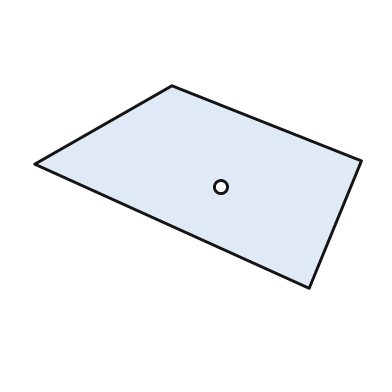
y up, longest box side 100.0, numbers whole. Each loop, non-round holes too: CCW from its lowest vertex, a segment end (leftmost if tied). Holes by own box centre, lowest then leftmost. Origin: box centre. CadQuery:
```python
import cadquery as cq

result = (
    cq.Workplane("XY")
    .moveTo(34.0, -31.0)
    .lineTo(50.0, 8.0)
    .lineTo(-8.0, 31.0)
    .lineTo(-50.0, 7.0)
    .close()
    .moveTo(7.0, 0.0)
    .circle(2.0)
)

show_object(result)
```